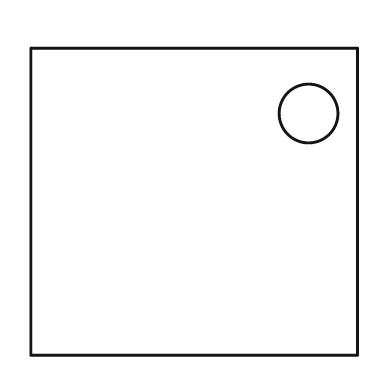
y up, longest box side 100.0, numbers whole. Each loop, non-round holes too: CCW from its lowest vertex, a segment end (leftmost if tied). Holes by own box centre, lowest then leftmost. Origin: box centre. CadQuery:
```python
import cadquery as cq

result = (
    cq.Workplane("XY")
    .moveTo(-50.0, -47.0)
    .lineTo(50.0, -47.0)
    .lineTo(50.0, 47.0)
    .lineTo(-50.0, 47.0)
    .close()
    .moveTo(35.0, 27.0)
    .circle(9.0)
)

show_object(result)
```